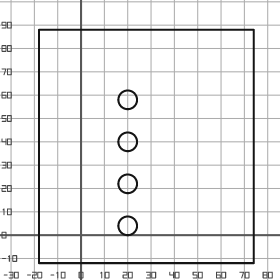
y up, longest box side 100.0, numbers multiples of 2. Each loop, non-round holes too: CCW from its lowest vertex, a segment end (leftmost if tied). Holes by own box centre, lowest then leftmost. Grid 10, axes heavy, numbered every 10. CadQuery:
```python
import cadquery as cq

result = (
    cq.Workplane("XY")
    .moveTo(-18.0, -12.0)
    .lineTo(74.0, -12.0)
    .lineTo(74.0, 88.0)
    .lineTo(-18.0, 88.0)
    .close()
    .moveTo(20.0, 4.0)
    .circle(4.0)
    .moveTo(20.0, 22.0)
    .circle(4.0)
    .moveTo(20.0, 40.0)
    .circle(4.0)
    .moveTo(20.0, 58.0)
    .circle(4.0)
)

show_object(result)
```